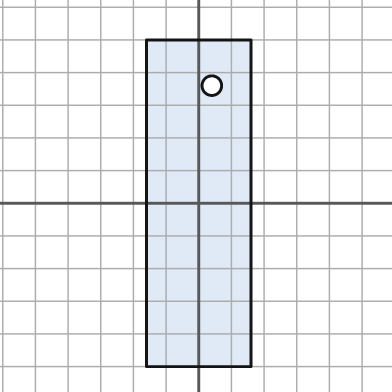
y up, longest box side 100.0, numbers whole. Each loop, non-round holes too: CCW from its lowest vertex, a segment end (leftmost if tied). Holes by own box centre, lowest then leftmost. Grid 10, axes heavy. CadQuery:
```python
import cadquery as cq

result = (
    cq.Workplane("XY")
    .moveTo(-16.0, -50.0)
    .lineTo(16.0, -50.0)
    .lineTo(16.0, 50.0)
    .lineTo(-16.0, 50.0)
    .close()
    .moveTo(4.0, 36.0)
    .circle(3.0)
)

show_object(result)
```